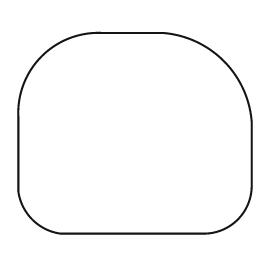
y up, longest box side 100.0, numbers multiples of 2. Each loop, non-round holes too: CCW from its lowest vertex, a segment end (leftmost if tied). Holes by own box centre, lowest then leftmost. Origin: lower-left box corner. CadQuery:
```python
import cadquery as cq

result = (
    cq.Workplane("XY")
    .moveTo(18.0, 0.0)
    .lineTo(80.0, 0.0)
    .threePointArc((94.0, 6.0), (100.0, 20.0))
    .lineTo(100.0, 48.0)
    .threePointArc((88.0, 74.0), (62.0, 86.0))
    .lineTo(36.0, 86.0)
    .threePointArc((10.0, 76.0), (0.0, 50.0))
    .lineTo(0.0, 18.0)
    .threePointArc((6.0, 6.0), (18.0, 0.0))
    .close()
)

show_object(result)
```